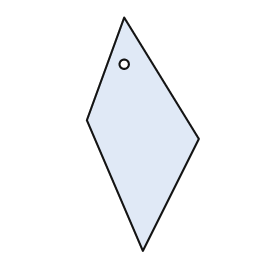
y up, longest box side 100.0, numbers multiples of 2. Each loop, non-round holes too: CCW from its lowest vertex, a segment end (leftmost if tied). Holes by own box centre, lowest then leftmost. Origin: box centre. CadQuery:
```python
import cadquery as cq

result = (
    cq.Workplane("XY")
    .moveTo(0.0, -50.0)
    .lineTo(24.0, -2.0)
    .lineTo(-8.0, 50.0)
    .lineTo(-24.0, 6.0)
    .close()
    .moveTo(-8.0, 30.0)
    .circle(2.0)
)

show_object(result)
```